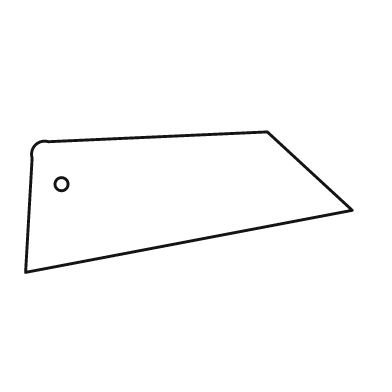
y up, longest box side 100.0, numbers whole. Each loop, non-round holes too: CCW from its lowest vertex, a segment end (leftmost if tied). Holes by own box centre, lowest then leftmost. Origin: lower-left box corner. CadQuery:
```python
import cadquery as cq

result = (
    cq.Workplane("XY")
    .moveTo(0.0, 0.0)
    .lineTo(100.0, 19.0)
    .lineTo(74.0, 43.0)
    .lineTo(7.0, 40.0)
    .threePointArc((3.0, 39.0), (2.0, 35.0))
    .close()
    .moveTo(11.0, 27.0)
    .circle(2.0)
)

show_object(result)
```